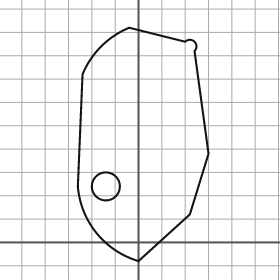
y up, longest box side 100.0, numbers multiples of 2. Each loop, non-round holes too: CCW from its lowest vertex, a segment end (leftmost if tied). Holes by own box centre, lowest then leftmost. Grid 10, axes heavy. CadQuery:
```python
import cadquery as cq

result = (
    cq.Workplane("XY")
    .moveTo(0.0, -8.0)
    .lineTo(22.0, 12.0)
    .lineTo(30.0, 38.0)
    .lineTo(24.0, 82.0)
    .threePointArc((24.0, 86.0), (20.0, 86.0))
    .lineTo(-4.0, 92.0)
    .threePointArc((-16.0, 84.0), (-24.0, 72.0))
    .lineTo(-26.0, 24.0)
    .threePointArc((-18.0, 4.0), (0.0, -8.0))
    .close()
    .moveTo(-14.0, 24.0)
    .circle(6.0)
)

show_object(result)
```